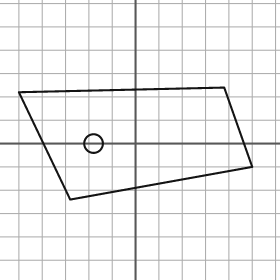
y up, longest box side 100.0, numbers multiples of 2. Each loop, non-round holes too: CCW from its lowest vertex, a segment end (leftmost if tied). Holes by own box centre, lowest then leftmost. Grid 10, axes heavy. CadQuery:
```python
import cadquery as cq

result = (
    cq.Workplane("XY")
    .moveTo(-28.0, -24.0)
    .lineTo(50.0, -10.0)
    .lineTo(38.0, 24.0)
    .lineTo(-50.0, 22.0)
    .close()
    .moveTo(-18.0, 0.0)
    .circle(4.0)
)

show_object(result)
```